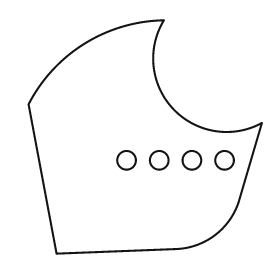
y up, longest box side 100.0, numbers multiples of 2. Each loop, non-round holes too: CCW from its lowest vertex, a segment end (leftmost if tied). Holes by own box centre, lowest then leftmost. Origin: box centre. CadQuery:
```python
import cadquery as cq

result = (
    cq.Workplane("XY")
    .moveTo(-38.0, -50.0)
    .lineTo(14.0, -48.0)
    .threePointArc((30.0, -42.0), (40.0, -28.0))
    .lineTo(50.0, 6.0)
    .threePointArc((12.0, 12.0), (8.0, 50.0))
    .threePointArc((-26.0, 40.0), (-50.0, 14.0))
    .close()
    .moveTo(-8.0, -10.0)
    .circle(4.0)
    .moveTo(6.0, -10.0)
    .circle(4.0)
    .moveTo(20.0, -10.0)
    .circle(4.0)
    .moveTo(34.0, -10.0)
    .circle(4.0)
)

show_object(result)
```